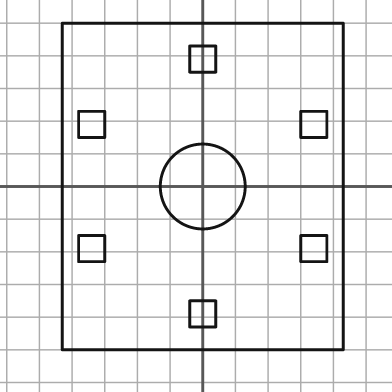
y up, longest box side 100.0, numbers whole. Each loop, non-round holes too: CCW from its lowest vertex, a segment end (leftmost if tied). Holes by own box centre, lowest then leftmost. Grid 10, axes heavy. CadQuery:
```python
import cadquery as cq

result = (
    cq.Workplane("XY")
    .moveTo(-43.0, -50.0)
    .lineTo(43.0, -50.0)
    .lineTo(43.0, 50.0)
    .lineTo(-43.0, 50.0)
    .close()
    .moveTo(-4.0, -43.0)
    .lineTo(4.0, -43.0)
    .lineTo(4.0, -35.0)
    .lineTo(-4.0, -35.0)
    .close()
    .moveTo(-38.0, -23.0)
    .lineTo(-30.0, -23.0)
    .lineTo(-30.0, -15.0)
    .lineTo(-38.0, -15.0)
    .close()
    .moveTo(30.0, -23.0)
    .lineTo(38.0, -23.0)
    .lineTo(38.0, -15.0)
    .lineTo(30.0, -15.0)
    .close()
    .moveTo(0.0, 0.0)
    .circle(13.0)
    .moveTo(-38.0, 15.0)
    .lineTo(-30.0, 15.0)
    .lineTo(-30.0, 23.0)
    .lineTo(-38.0, 23.0)
    .close()
    .moveTo(30.0, 15.0)
    .lineTo(38.0, 15.0)
    .lineTo(38.0, 23.0)
    .lineTo(30.0, 23.0)
    .close()
    .moveTo(-4.0, 35.0)
    .lineTo(4.0, 35.0)
    .lineTo(4.0, 43.0)
    .lineTo(-4.0, 43.0)
    .close()
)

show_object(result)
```